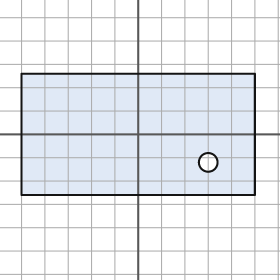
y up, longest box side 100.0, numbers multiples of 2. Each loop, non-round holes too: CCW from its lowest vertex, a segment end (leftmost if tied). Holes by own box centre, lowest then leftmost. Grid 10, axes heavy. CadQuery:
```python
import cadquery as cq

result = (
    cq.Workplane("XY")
    .moveTo(-50.0, -26.0)
    .lineTo(50.0, -26.0)
    .lineTo(50.0, 26.0)
    .lineTo(-50.0, 26.0)
    .close()
    .moveTo(30.0, -12.0)
    .circle(4.0)
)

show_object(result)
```